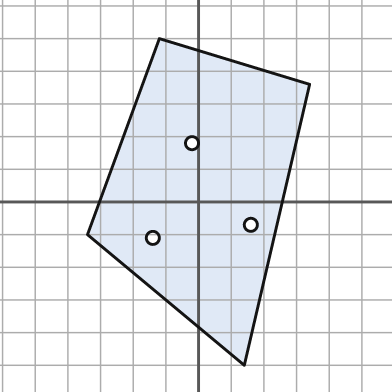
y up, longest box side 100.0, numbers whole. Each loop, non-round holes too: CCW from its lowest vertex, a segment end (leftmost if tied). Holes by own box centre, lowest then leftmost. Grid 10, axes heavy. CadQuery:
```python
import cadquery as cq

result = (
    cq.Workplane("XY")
    .moveTo(14.0, -50.0)
    .lineTo(34.0, 36.0)
    .lineTo(-12.0, 50.0)
    .lineTo(-34.0, -10.0)
    .close()
    .moveTo(-14.0, -11.0)
    .circle(2.0)
    .moveTo(16.0, -7.0)
    .circle(2.0)
    .moveTo(-2.0, 18.0)
    .circle(2.0)
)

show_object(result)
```